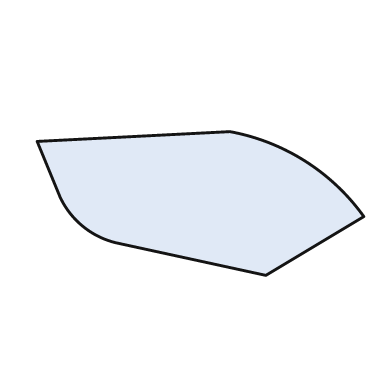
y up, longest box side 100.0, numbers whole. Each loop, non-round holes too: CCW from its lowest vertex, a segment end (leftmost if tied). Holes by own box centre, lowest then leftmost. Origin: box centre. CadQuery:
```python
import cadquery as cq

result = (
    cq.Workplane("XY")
    .moveTo(20.0, -22.0)
    .lineTo(50.0, -4.0)
    .threePointArc((32.0, 13.0), (9.0, 22.0))
    .lineTo(-50.0, 19.0)
    .lineTo(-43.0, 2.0)
    .threePointArc((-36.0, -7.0), (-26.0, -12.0))
    .close()
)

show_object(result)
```